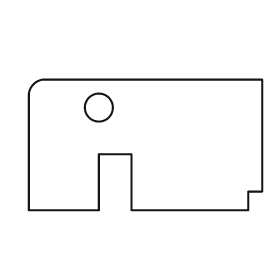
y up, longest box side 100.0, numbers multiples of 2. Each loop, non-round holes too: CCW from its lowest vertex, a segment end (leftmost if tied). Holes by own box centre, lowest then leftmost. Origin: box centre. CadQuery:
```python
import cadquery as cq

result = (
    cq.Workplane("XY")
    .moveTo(-50.0, -28.0)
    .lineTo(-20.0, -28.0)
    .lineTo(-20.0, -4.0)
    .lineTo(-6.0, -4.0)
    .lineTo(-6.0, -28.0)
    .lineTo(44.0, -28.0)
    .lineTo(44.0, -20.0)
    .lineTo(50.0, -20.0)
    .lineTo(50.0, 28.0)
    .lineTo(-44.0, 28.0)
    .threePointArc((-48.0, 26.0), (-50.0, 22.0))
    .close()
    .moveTo(-20.0, 16.0)
    .circle(6.0)
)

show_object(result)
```